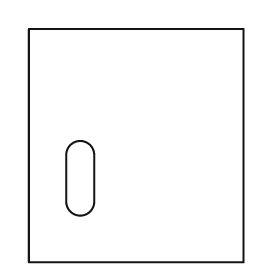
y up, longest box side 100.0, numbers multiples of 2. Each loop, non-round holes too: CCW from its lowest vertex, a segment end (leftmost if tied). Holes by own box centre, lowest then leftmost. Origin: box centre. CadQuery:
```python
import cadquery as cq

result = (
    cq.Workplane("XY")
    .moveTo(-46.0, -50.0)
    .lineTo(46.0, -50.0)
    .lineTo(46.0, 50.0)
    .lineTo(-46.0, 50.0)
    .close()
    .moveTo(-30.0, -24.0)
    .threePointArc((-24.0, -30.0), (-18.0, -24.0))
    .lineTo(-18.0, -4.0)
    .threePointArc((-24.0, 2.0), (-30.0, -4.0))
    .close()
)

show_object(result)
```